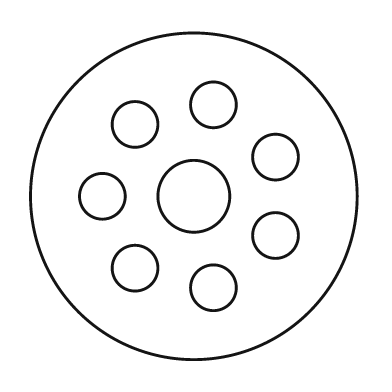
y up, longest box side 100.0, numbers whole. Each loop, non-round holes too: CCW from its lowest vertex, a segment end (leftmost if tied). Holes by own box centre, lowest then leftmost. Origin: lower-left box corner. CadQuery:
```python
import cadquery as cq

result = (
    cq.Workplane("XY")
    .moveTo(50.0, 50.0)
    .circle(50.0)
    .moveTo(56.0, 22.0)
    .circle(7.0)
    .moveTo(32.0, 28.0)
    .circle(7.0)
    .moveTo(75.0, 38.0)
    .circle(7.0)
    .moveTo(22.0, 50.0)
    .circle(7.0)
    .moveTo(50.0, 50.0)
    .circle(11.0)
    .moveTo(75.0, 62.0)
    .circle(7.0)
    .moveTo(32.0, 72.0)
    .circle(7.0)
    .moveTo(56.0, 78.0)
    .circle(7.0)
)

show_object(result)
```